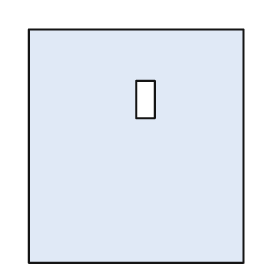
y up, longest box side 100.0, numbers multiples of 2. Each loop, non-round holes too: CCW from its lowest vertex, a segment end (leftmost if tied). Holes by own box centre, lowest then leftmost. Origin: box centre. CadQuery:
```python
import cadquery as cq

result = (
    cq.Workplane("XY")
    .moveTo(-46.0, -50.0)
    .lineTo(46.0, -50.0)
    .lineTo(46.0, 50.0)
    .lineTo(-46.0, 50.0)
    .close()
    .moveTo(0.0, 12.0)
    .lineTo(8.0, 12.0)
    .lineTo(8.0, 28.0)
    .lineTo(0.0, 28.0)
    .close()
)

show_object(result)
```